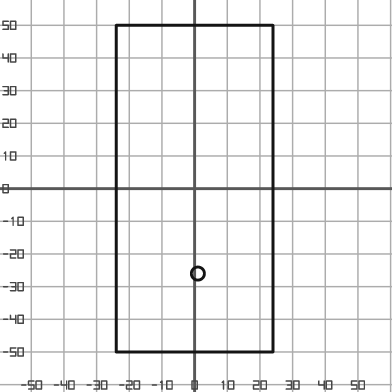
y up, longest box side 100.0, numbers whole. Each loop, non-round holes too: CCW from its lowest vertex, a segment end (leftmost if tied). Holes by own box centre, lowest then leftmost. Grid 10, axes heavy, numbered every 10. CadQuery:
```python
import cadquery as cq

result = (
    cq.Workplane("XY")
    .moveTo(-24.0, -50.0)
    .lineTo(24.0, -50.0)
    .lineTo(24.0, 50.0)
    .lineTo(-24.0, 50.0)
    .close()
    .moveTo(1.0, -26.0)
    .circle(2.0)
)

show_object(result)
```